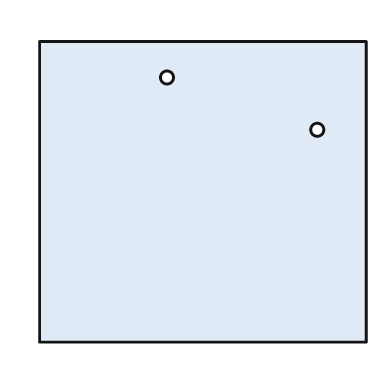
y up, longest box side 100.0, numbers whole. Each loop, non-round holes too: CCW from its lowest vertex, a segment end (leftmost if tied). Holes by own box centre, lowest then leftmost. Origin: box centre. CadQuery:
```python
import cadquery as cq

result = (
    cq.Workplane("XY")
    .moveTo(-50.0, -46.0)
    .lineTo(50.0, -46.0)
    .lineTo(50.0, 46.0)
    .lineTo(-50.0, 46.0)
    .close()
    .moveTo(35.0, 19.0)
    .circle(2.0)
    .moveTo(-11.0, 35.0)
    .circle(2.0)
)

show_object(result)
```